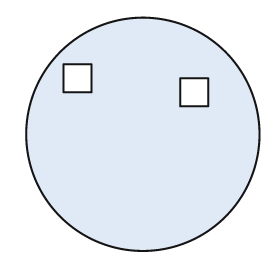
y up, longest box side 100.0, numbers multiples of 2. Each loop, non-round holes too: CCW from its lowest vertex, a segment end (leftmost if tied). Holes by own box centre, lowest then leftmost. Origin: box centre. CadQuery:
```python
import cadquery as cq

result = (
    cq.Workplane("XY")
    .moveTo(0.0, 0.0)
    .circle(50.0)
    .moveTo(16.0, 12.0)
    .lineTo(28.0, 12.0)
    .lineTo(28.0, 24.0)
    .lineTo(16.0, 24.0)
    .close()
    .moveTo(-34.0, 18.0)
    .lineTo(-22.0, 18.0)
    .lineTo(-22.0, 30.0)
    .lineTo(-34.0, 30.0)
    .close()
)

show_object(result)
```